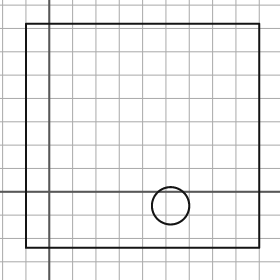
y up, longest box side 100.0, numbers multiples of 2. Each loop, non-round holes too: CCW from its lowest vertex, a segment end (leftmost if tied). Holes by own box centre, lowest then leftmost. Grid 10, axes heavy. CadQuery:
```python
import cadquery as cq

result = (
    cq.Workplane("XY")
    .moveTo(-10.0, -24.0)
    .lineTo(90.0, -24.0)
    .lineTo(90.0, 72.0)
    .lineTo(-10.0, 72.0)
    .close()
    .moveTo(52.0, -6.0)
    .circle(8.0)
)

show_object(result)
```